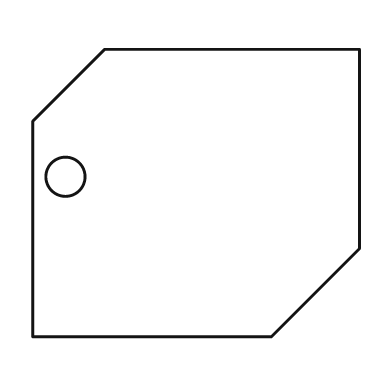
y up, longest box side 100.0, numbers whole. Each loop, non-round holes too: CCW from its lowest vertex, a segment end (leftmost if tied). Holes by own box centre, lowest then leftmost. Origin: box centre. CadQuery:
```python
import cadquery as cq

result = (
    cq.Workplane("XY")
    .moveTo(-50.0, -44.0)
    .lineTo(23.0, -44.0)
    .lineTo(50.0, -17.0)
    .lineTo(50.0, 44.0)
    .lineTo(-28.0, 44.0)
    .lineTo(-50.0, 22.0)
    .close()
    .moveTo(-40.0, 5.0)
    .circle(6.0)
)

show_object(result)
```